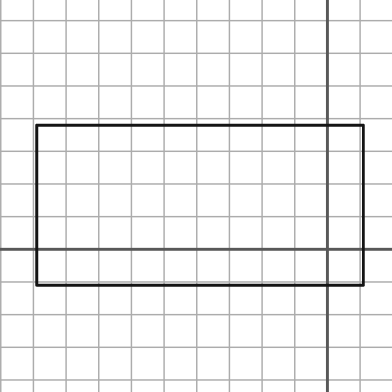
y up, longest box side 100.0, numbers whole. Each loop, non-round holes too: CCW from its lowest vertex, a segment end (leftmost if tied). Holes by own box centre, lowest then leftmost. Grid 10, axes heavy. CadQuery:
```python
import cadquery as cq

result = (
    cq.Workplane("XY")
    .moveTo(-89.0, -11.0)
    .lineTo(11.0, -11.0)
    .lineTo(11.0, 38.0)
    .lineTo(-89.0, 38.0)
    .close()
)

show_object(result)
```